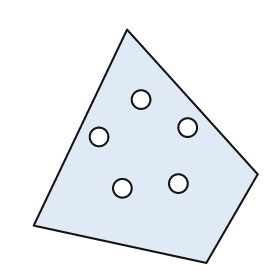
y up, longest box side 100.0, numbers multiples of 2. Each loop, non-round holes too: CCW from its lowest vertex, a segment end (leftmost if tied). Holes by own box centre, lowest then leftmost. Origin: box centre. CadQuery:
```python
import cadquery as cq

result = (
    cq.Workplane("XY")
    .moveTo(26.0, -50.0)
    .lineTo(48.0, -12.0)
    .lineTo(-8.0, 50.0)
    .lineTo(-48.0, -34.0)
    .close()
    .moveTo(-10.0, -18.0)
    .circle(4.0)
    .moveTo(14.0, -16.0)
    .circle(4.0)
    .moveTo(-20.0, 4.0)
    .circle(4.0)
    .moveTo(18.0, 8.0)
    .circle(4.0)
    .moveTo(-2.0, 20.0)
    .circle(4.0)
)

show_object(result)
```